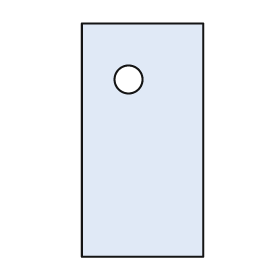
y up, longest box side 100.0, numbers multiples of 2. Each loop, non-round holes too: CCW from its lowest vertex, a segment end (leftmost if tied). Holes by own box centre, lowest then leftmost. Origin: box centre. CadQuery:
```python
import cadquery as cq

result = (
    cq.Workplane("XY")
    .moveTo(-26.0, -50.0)
    .lineTo(26.0, -50.0)
    .lineTo(26.0, 50.0)
    .lineTo(-26.0, 50.0)
    .close()
    .moveTo(-6.0, 26.0)
    .circle(6.0)
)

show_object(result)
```